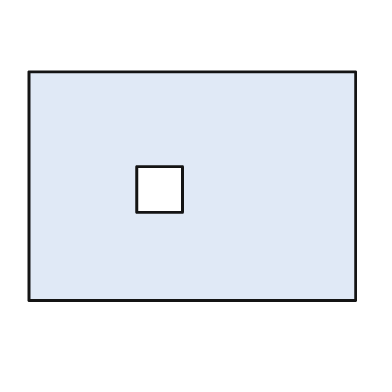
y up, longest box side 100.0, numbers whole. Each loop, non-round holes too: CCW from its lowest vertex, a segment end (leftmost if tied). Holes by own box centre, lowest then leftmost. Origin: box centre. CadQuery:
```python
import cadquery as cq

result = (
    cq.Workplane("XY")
    .moveTo(-50.0, -35.0)
    .lineTo(50.0, -35.0)
    .lineTo(50.0, 35.0)
    .lineTo(-50.0, 35.0)
    .close()
    .moveTo(-17.0, -8.0)
    .lineTo(-3.0, -8.0)
    .lineTo(-3.0, 6.0)
    .lineTo(-17.0, 6.0)
    .close()
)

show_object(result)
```